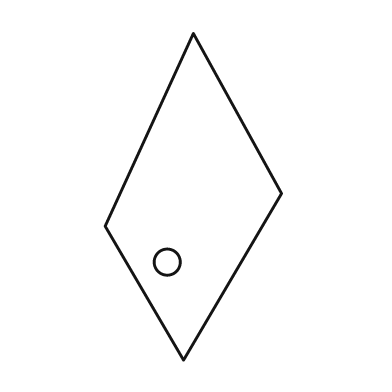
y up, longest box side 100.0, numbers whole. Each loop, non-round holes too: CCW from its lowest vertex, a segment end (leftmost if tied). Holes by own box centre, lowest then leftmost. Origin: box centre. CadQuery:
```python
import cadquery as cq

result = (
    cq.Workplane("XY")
    .moveTo(-3.0, -50.0)
    .lineTo(27.0, 1.0)
    .lineTo(0.0, 50.0)
    .lineTo(-27.0, -9.0)
    .close()
    .moveTo(-8.0, -20.0)
    .circle(4.0)
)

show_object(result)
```